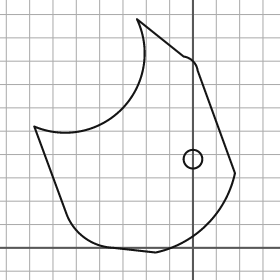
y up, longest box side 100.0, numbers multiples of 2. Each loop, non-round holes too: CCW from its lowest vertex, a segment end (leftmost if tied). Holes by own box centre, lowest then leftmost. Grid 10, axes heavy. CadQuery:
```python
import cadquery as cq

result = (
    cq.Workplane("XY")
    .moveTo(-16.0, -2.0)
    .threePointArc((6.0, 10.0), (18.0, 32.0))
    .lineTo(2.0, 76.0)
    .threePointArc((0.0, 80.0), (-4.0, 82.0))
    .lineTo(-24.0, 98.0)
    .threePointArc((-30.0, 60.0), (-68.0, 52.0))
    .lineTo(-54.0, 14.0)
    .threePointArc((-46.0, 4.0), (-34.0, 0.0))
    .close()
    .moveTo(0.0, 38.0)
    .circle(4.0)
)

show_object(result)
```